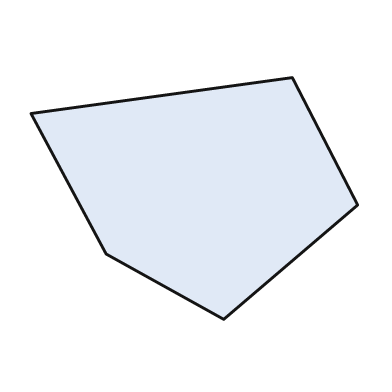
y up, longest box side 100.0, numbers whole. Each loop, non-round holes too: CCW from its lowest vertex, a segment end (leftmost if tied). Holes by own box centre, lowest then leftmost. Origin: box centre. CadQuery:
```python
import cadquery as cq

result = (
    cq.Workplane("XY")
    .moveTo(9.0, -37.0)
    .lineTo(50.0, -2.0)
    .lineTo(30.0, 37.0)
    .lineTo(-50.0, 26.0)
    .lineTo(-27.0, -17.0)
    .close()
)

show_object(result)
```